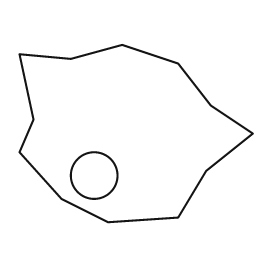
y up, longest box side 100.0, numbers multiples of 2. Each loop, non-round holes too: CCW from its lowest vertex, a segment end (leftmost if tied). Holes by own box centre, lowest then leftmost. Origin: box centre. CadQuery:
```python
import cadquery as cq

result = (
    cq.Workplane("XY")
    .moveTo(-12.0, -38.0)
    .lineTo(18.0, -36.0)
    .lineTo(30.0, -16.0)
    .lineTo(50.0, 0.0)
    .lineTo(32.0, 12.0)
    .lineTo(18.0, 30.0)
    .lineTo(-6.0, 38.0)
    .lineTo(-28.0, 32.0)
    .lineTo(-50.0, 34.0)
    .lineTo(-44.0, 6.0)
    .lineTo(-50.0, -8.0)
    .lineTo(-32.0, -28.0)
    .close()
    .moveTo(-18.0, -18.0)
    .circle(10.0)
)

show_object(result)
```